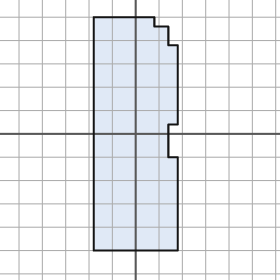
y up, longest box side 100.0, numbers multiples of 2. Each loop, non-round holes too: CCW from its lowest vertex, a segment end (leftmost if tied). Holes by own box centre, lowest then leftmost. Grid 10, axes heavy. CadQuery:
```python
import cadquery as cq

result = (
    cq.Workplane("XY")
    .moveTo(-18.0, -50.0)
    .lineTo(18.0, -50.0)
    .lineTo(18.0, -10.0)
    .lineTo(14.0, -10.0)
    .lineTo(14.0, 4.0)
    .lineTo(18.0, 4.0)
    .lineTo(18.0, 38.0)
    .lineTo(14.0, 38.0)
    .lineTo(14.0, 46.0)
    .lineTo(8.0, 46.0)
    .lineTo(8.0, 50.0)
    .lineTo(-18.0, 50.0)
    .close()
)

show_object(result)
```